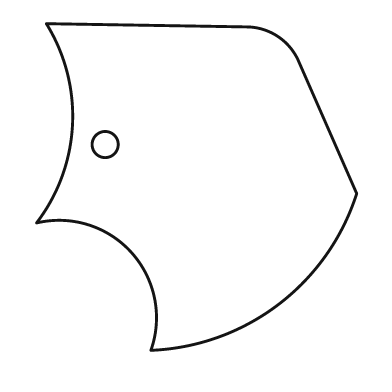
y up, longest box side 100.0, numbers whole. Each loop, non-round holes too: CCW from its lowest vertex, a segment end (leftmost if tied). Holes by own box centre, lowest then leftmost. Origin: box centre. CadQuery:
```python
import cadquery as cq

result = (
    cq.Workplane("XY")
    .moveTo(-14.0, -50.0)
    .threePointArc((25.0, -36.0), (49.0, -2.0))
    .lineTo(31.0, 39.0)
    .threePointArc((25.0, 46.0), (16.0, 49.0))
    .lineTo(-46.0, 50.0)
    .threePointArc((-38.0, 19.0), (-49.0, -11.0))
    .threePointArc((-20.0, -20.0), (-14.0, -50.0))
    .close()
    .moveTo(-28.0, 13.0)
    .circle(4.0)
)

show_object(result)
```